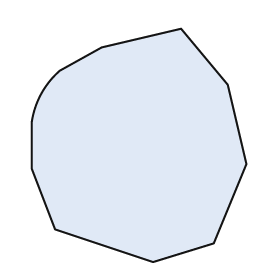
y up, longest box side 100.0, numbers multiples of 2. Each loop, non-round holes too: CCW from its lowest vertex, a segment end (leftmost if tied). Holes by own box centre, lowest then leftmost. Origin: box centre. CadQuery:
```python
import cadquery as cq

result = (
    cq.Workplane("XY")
    .moveTo(6.0, -50.0)
    .lineTo(32.0, -42.0)
    .lineTo(46.0, -8.0)
    .lineTo(38.0, 26.0)
    .lineTo(18.0, 50.0)
    .lineTo(-16.0, 42.0)
    .lineTo(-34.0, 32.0)
    .threePointArc((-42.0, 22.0), (-46.0, 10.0))
    .lineTo(-46.0, -10.0)
    .lineTo(-36.0, -36.0)
    .close()
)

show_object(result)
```